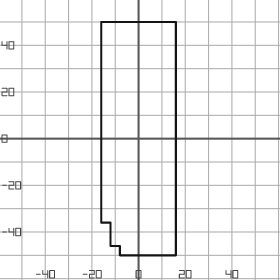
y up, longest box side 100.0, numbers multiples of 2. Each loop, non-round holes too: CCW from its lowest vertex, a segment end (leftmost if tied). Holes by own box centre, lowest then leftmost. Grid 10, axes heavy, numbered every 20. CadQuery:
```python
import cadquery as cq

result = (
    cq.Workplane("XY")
    .moveTo(-8.0, -50.0)
    .lineTo(16.0, -50.0)
    .lineTo(16.0, 50.0)
    .lineTo(-16.0, 50.0)
    .lineTo(-16.0, -36.0)
    .lineTo(-12.0, -36.0)
    .lineTo(-12.0, -46.0)
    .lineTo(-8.0, -46.0)
    .close()
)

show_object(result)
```